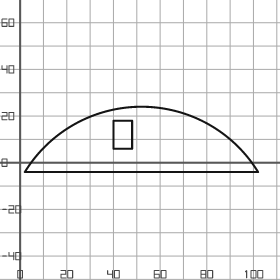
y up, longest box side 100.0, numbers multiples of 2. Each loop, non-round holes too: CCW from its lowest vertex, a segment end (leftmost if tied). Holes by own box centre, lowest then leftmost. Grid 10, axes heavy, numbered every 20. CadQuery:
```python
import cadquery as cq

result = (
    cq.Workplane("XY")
    .moveTo(2.0, -4.0)
    .lineTo(102.0, -4.0)
    .threePointArc((52.0, 24.0), (2.0, -4.0))
    .close()
    .moveTo(40.0, 6.0)
    .lineTo(48.0, 6.0)
    .lineTo(48.0, 18.0)
    .lineTo(40.0, 18.0)
    .close()
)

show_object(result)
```